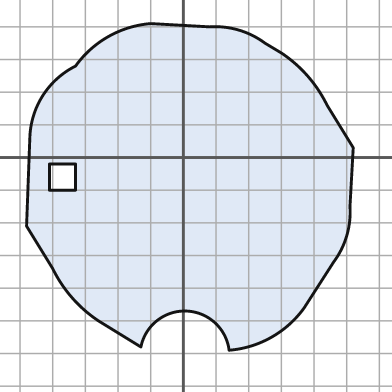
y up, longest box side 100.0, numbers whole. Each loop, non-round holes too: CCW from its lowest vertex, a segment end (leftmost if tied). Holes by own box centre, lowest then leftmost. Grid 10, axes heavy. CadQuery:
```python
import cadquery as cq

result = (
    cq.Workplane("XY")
    .moveTo(14.0, -59.0)
    .threePointArc((27.0, -55.0), (37.0, -46.0))
    .lineTo(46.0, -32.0)
    .threePointArc((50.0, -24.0), (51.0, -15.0))
    .lineTo(52.0, 3.0)
    .lineTo(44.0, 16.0)
    .threePointArc((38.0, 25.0), (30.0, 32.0))
    .lineTo(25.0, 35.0)
    .threePointArc((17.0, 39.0), (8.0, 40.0))
    .lineTo(-10.0, 41.0)
    .threePointArc((-23.0, 37.0), (-33.0, 28.0))
    .threePointArc((-43.0, 19.0), (-47.0, 6.0))
    .lineTo(-48.0, -21.0)
    .lineTo(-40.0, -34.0)
    .threePointArc((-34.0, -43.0), (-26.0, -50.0))
    .lineTo(-13.0, -58.0)
    .threePointArc((1.0, -47.0), (14.0, -59.0))
    .close()
    .moveTo(-41.0, -10.0)
    .lineTo(-33.0, -10.0)
    .lineTo(-33.0, -2.0)
    .lineTo(-41.0, -2.0)
    .close()
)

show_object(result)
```